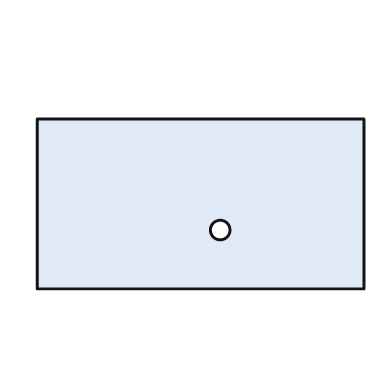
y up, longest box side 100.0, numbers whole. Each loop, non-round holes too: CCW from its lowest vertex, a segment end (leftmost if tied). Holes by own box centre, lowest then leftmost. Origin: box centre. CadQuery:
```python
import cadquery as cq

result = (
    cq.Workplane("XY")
    .moveTo(-50.0, -26.0)
    .lineTo(50.0, -26.0)
    .lineTo(50.0, 26.0)
    .lineTo(-50.0, 26.0)
    .close()
    .moveTo(6.0, -8.0)
    .circle(3.0)
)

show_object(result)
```